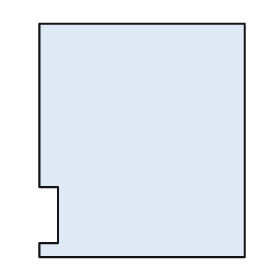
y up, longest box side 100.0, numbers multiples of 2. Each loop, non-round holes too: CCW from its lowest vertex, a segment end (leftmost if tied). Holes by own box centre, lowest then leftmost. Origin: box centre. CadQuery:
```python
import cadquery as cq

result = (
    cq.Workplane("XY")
    .moveTo(-44.0, -50.0)
    .lineTo(44.0, -50.0)
    .lineTo(44.0, 50.0)
    .lineTo(-44.0, 50.0)
    .lineTo(-44.0, -20.0)
    .lineTo(-36.0, -20.0)
    .lineTo(-36.0, -44.0)
    .lineTo(-44.0, -44.0)
    .close()
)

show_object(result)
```